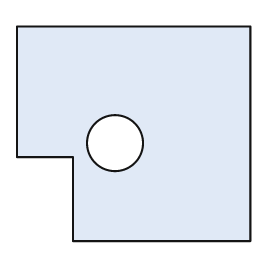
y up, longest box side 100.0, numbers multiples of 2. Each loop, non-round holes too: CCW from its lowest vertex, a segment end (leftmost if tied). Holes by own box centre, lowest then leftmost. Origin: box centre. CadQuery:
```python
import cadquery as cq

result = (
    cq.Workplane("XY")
    .moveTo(-26.0, -46.0)
    .lineTo(50.0, -46.0)
    .lineTo(50.0, 46.0)
    .lineTo(-50.0, 46.0)
    .lineTo(-50.0, -10.0)
    .lineTo(-26.0, -10.0)
    .close()
    .moveTo(-8.0, -4.0)
    .circle(12.0)
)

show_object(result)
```